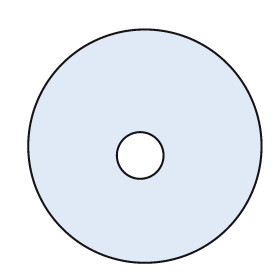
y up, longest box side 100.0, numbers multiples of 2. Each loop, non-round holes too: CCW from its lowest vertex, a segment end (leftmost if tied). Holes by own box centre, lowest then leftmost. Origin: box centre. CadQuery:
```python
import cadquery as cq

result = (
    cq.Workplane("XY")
    .moveTo(0.0, 0.0)
    .circle(50.0)
    .moveTo(-2.0, -4.0)
    .circle(10.0)
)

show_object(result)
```